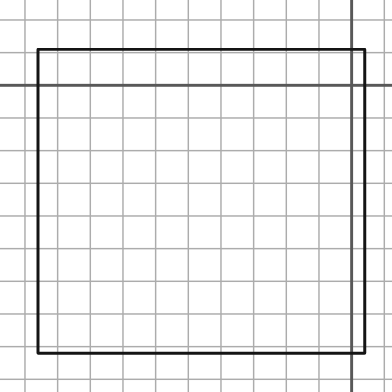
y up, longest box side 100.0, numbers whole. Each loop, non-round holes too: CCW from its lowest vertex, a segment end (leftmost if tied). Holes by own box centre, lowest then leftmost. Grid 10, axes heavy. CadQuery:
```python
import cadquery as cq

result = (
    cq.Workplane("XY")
    .moveTo(-96.0, -82.0)
    .lineTo(4.0, -82.0)
    .lineTo(4.0, 11.0)
    .lineTo(-96.0, 11.0)
    .close()
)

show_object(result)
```